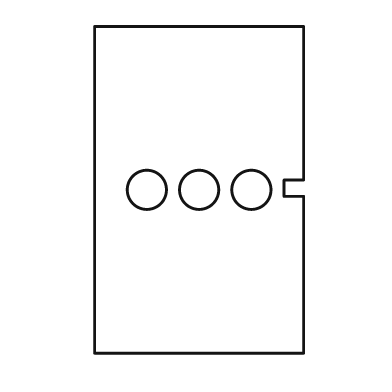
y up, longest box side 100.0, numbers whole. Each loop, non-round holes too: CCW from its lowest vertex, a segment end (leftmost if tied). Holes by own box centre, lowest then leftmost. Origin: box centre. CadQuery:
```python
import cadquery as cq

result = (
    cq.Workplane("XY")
    .moveTo(-32.0, -50.0)
    .lineTo(32.0, -50.0)
    .lineTo(32.0, -2.0)
    .lineTo(26.0, -2.0)
    .lineTo(26.0, 3.0)
    .lineTo(32.0, 3.0)
    .lineTo(32.0, 50.0)
    .lineTo(-32.0, 50.0)
    .close()
    .moveTo(-16.0, 0.0)
    .circle(6.0)
    .moveTo(0.0, 0.0)
    .circle(6.0)
    .moveTo(16.0, 0.0)
    .circle(6.0)
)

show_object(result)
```